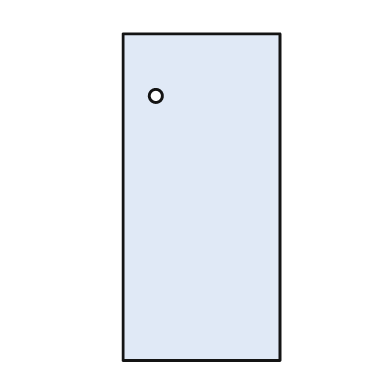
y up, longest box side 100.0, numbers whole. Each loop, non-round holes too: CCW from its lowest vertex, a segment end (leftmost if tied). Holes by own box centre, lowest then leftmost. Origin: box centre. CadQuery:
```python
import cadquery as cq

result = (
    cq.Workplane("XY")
    .moveTo(-24.0, -50.0)
    .lineTo(24.0, -50.0)
    .lineTo(24.0, 50.0)
    .lineTo(-24.0, 50.0)
    .close()
    .moveTo(-14.0, 31.0)
    .circle(2.0)
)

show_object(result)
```